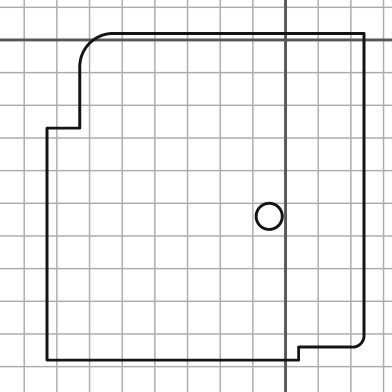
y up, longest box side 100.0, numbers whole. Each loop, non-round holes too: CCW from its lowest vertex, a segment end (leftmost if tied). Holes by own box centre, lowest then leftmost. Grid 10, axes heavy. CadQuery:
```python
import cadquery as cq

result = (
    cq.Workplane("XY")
    .moveTo(-73.0, -98.0)
    .lineTo(4.0, -98.0)
    .lineTo(4.0, -94.0)
    .lineTo(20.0, -94.0)
    .threePointArc((23.0, -93.0), (24.0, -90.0))
    .lineTo(24.0, 2.0)
    .lineTo(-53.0, 2.0)
    .threePointArc((-60.0, -1.0), (-63.0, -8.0))
    .lineTo(-63.0, -27.0)
    .lineTo(-73.0, -27.0)
    .close()
    .moveTo(-5.0, -54.0)
    .circle(4.0)
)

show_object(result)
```